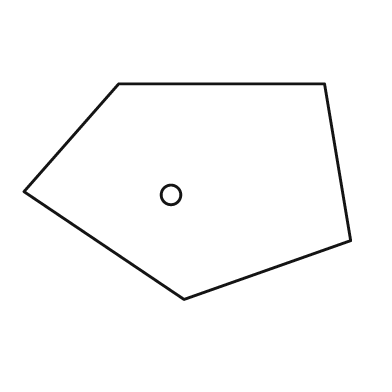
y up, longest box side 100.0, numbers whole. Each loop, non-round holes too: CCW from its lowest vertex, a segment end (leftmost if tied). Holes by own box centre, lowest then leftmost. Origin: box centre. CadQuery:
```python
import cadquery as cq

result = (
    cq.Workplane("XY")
    .moveTo(-1.0, -33.0)
    .lineTo(50.0, -15.0)
    .lineTo(42.0, 33.0)
    .lineTo(-21.0, 33.0)
    .lineTo(-50.0, 0.0)
    .close()
    .moveTo(-5.0, -1.0)
    .circle(3.0)
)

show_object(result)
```